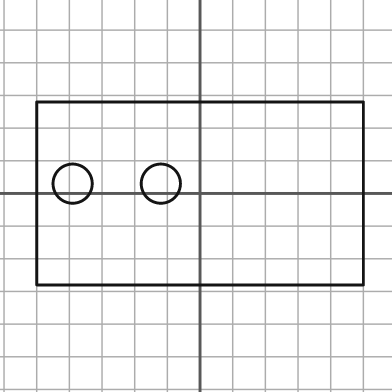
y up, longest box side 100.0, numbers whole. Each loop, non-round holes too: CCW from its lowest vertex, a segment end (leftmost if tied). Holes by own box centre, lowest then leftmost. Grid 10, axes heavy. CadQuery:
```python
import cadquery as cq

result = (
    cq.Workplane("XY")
    .moveTo(-50.0, -28.0)
    .lineTo(50.0, -28.0)
    .lineTo(50.0, 28.0)
    .lineTo(-50.0, 28.0)
    .close()
    .moveTo(-39.0, 3.0)
    .circle(6.0)
    .moveTo(-12.0, 3.0)
    .circle(6.0)
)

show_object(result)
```